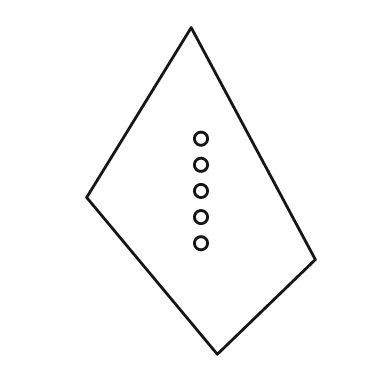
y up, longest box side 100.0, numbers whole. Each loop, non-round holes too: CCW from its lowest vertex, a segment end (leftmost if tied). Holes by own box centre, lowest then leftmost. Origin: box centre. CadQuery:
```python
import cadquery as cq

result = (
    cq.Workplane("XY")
    .moveTo(5.0, -50.0)
    .lineTo(35.0, -21.0)
    .lineTo(-3.0, 50.0)
    .lineTo(-35.0, -2.0)
    .close()
    .moveTo(0.0, -16.0)
    .circle(2.0)
    .moveTo(0.0, -8.0)
    .circle(2.0)
    .moveTo(0.0, 0.0)
    .circle(2.0)
    .moveTo(0.0, 8.0)
    .circle(2.0)
    .moveTo(0.0, 16.0)
    .circle(2.0)
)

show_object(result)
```